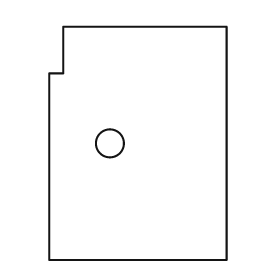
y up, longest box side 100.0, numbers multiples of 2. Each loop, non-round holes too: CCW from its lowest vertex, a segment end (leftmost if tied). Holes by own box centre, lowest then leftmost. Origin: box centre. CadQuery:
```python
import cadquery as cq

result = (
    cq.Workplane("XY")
    .moveTo(-38.0, -50.0)
    .lineTo(38.0, -50.0)
    .lineTo(38.0, 50.0)
    .lineTo(-32.0, 50.0)
    .lineTo(-32.0, 30.0)
    .lineTo(-38.0, 30.0)
    .close()
    .moveTo(-12.0, 0.0)
    .circle(6.0)
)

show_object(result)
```